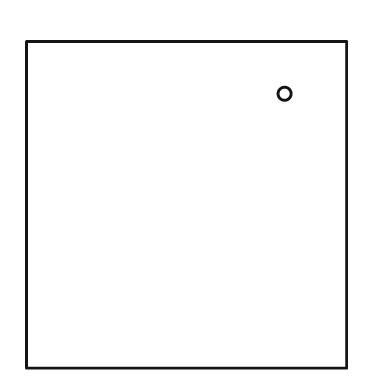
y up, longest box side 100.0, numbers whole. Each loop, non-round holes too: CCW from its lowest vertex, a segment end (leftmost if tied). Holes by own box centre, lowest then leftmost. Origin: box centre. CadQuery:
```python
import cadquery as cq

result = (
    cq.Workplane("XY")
    .moveTo(-49.0, -50.0)
    .lineTo(49.0, -50.0)
    .lineTo(49.0, 50.0)
    .lineTo(-49.0, 50.0)
    .close()
    .moveTo(30.0, 34.0)
    .circle(2.0)
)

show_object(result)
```